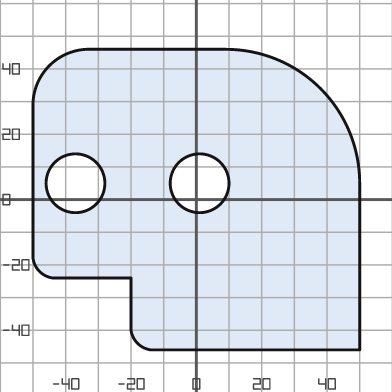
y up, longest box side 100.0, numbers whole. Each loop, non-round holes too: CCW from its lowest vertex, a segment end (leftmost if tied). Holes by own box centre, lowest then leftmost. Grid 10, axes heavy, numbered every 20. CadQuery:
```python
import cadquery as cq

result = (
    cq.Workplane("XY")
    .moveTo(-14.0, -46.0)
    .lineTo(50.0, -46.0)
    .lineTo(50.0, 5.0)
    .threePointArc((38.0, 34.0), (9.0, 46.0))
    .lineTo(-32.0, 46.0)
    .threePointArc((-45.0, 41.0), (-50.0, 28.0))
    .lineTo(-50.0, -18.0)
    .threePointArc((-48.0, -22.0), (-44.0, -24.0))
    .lineTo(-20.0, -24.0)
    .lineTo(-20.0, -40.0)
    .threePointArc((-18.0, -44.0), (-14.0, -46.0))
    .close()
    .moveTo(-37.0, 5.0)
    .circle(9.0)
    .moveTo(1.0, 5.0)
    .circle(9.0)
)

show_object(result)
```